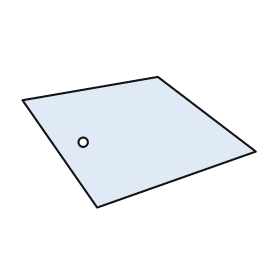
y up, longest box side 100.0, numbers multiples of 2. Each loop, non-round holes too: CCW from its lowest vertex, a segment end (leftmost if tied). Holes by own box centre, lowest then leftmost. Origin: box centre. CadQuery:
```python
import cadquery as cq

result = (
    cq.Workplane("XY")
    .moveTo(-18.0, -28.0)
    .lineTo(50.0, -4.0)
    .lineTo(8.0, 28.0)
    .lineTo(-50.0, 18.0)
    .close()
    .moveTo(-24.0, 0.0)
    .circle(2.0)
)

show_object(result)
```